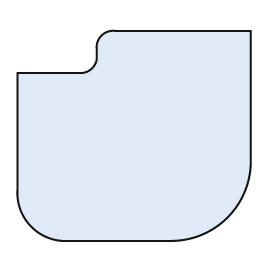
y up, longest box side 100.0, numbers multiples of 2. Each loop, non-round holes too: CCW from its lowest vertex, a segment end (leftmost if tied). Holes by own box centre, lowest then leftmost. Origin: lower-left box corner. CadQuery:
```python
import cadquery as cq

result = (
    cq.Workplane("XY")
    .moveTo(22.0, 0.0)
    .lineTo(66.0, 0.0)
    .threePointArc((90.0, 10.0), (100.0, 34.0))
    .lineTo(100.0, 90.0)
    .lineTo(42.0, 90.0)
    .threePointArc((36.0, 88.0), (34.0, 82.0))
    .lineTo(34.0, 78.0)
    .threePointArc((32.0, 74.0), (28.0, 72.0))
    .lineTo(0.0, 72.0)
    .lineTo(0.0, 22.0)
    .threePointArc((6.0, 6.0), (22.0, 0.0))
    .close()
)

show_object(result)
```